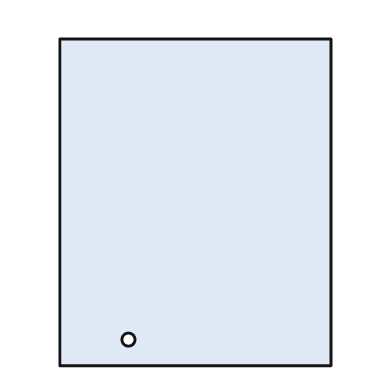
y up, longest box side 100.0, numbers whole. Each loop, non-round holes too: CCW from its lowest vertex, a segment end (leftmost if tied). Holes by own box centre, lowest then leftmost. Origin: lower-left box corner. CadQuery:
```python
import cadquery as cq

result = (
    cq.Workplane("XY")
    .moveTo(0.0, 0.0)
    .lineTo(83.0, 0.0)
    .lineTo(83.0, 100.0)
    .lineTo(0.0, 100.0)
    .close()
    .moveTo(21.0, 8.0)
    .circle(2.0)
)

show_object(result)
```